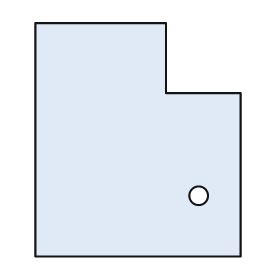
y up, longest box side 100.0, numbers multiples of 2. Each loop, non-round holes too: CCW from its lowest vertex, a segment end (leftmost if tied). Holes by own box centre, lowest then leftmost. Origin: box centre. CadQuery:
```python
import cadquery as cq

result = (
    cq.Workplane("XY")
    .moveTo(-44.0, -50.0)
    .lineTo(44.0, -50.0)
    .lineTo(44.0, 20.0)
    .lineTo(12.0, 20.0)
    .lineTo(12.0, 50.0)
    .lineTo(-44.0, 50.0)
    .close()
    .moveTo(26.0, -24.0)
    .circle(4.0)
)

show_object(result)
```